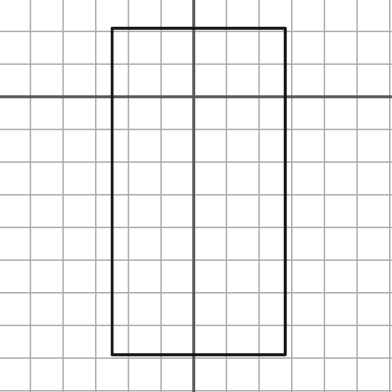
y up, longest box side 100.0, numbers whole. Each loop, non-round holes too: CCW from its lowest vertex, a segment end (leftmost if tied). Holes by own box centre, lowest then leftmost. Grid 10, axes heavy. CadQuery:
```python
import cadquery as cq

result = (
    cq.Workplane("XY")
    .moveTo(-25.0, -79.0)
    .lineTo(28.0, -79.0)
    .lineTo(28.0, 21.0)
    .lineTo(-25.0, 21.0)
    .close()
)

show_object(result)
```